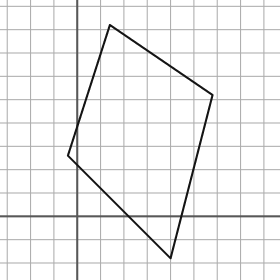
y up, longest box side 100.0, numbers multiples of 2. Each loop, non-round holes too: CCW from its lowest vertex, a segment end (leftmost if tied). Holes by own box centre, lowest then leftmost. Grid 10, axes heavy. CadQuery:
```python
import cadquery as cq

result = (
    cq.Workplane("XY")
    .moveTo(40.0, -18.0)
    .lineTo(58.0, 52.0)
    .lineTo(14.0, 82.0)
    .lineTo(-4.0, 26.0)
    .close()
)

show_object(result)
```